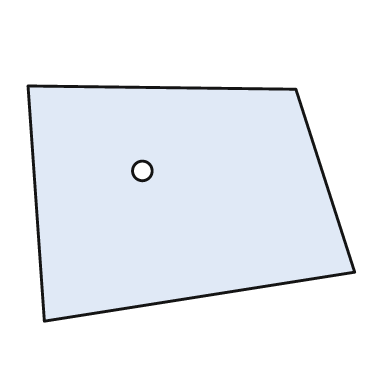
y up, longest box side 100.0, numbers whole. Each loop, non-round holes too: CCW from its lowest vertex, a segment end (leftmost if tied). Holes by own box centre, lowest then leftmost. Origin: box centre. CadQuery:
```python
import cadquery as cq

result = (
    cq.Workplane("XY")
    .moveTo(-45.0, -36.0)
    .lineTo(50.0, -21.0)
    .lineTo(32.0, 35.0)
    .lineTo(-50.0, 36.0)
    .close()
    .moveTo(-15.0, 10.0)
    .circle(3.0)
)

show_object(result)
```